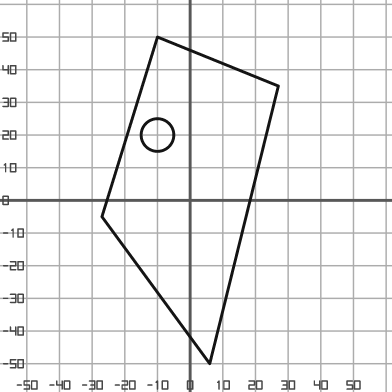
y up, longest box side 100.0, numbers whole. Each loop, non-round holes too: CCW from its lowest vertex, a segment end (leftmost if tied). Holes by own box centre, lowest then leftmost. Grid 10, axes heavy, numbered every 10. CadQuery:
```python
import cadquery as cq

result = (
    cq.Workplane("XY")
    .moveTo(6.0, -50.0)
    .lineTo(27.0, 35.0)
    .lineTo(-10.0, 50.0)
    .lineTo(-27.0, -5.0)
    .close()
    .moveTo(-10.0, 20.0)
    .circle(5.0)
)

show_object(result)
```